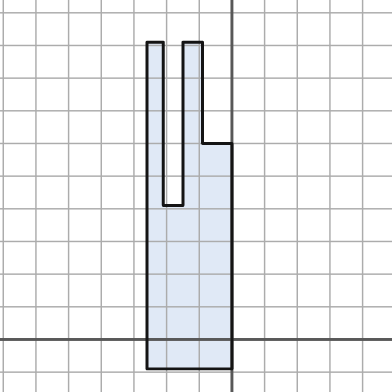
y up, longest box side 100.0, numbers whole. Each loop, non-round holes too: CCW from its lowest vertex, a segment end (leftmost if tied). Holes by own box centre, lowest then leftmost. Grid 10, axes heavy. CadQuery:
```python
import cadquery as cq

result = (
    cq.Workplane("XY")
    .moveTo(-26.0, -9.0)
    .lineTo(0.0, -9.0)
    .lineTo(0.0, 60.0)
    .lineTo(-9.0, 60.0)
    .lineTo(-9.0, 91.0)
    .lineTo(-15.0, 91.0)
    .lineTo(-15.0, 41.0)
    .lineTo(-21.0, 41.0)
    .lineTo(-21.0, 91.0)
    .lineTo(-26.0, 91.0)
    .close()
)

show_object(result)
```